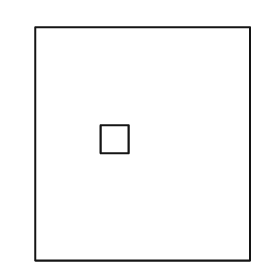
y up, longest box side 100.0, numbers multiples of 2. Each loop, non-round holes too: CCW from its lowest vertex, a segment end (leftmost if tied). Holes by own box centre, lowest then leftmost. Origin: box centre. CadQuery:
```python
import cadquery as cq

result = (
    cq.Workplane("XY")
    .moveTo(-46.0, -50.0)
    .lineTo(46.0, -50.0)
    .lineTo(46.0, 50.0)
    .lineTo(-46.0, 50.0)
    .close()
    .moveTo(-18.0, -4.0)
    .lineTo(-6.0, -4.0)
    .lineTo(-6.0, 8.0)
    .lineTo(-18.0, 8.0)
    .close()
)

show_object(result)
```